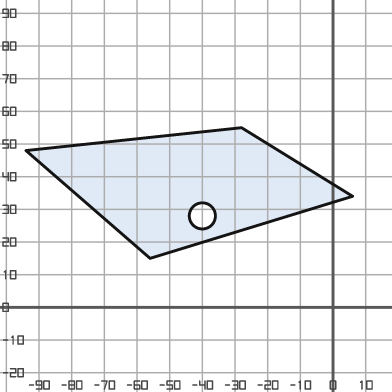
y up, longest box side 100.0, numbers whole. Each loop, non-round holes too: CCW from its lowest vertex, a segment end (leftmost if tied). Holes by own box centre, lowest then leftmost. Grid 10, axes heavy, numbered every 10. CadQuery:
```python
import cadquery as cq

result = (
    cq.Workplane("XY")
    .moveTo(-56.0, 15.0)
    .lineTo(6.0, 34.0)
    .lineTo(-28.0, 55.0)
    .lineTo(-94.0, 48.0)
    .close()
    .moveTo(-40.0, 28.0)
    .circle(4.0)
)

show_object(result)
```